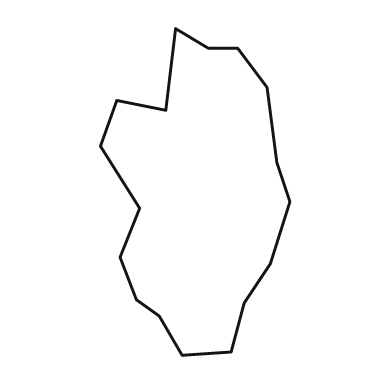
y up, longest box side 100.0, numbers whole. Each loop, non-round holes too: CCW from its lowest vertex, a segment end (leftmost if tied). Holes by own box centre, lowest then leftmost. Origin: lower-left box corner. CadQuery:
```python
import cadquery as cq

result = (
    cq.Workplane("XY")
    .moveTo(25.0, 0.0)
    .lineTo(40.0, 1.0)
    .lineTo(44.0, 16.0)
    .lineTo(52.0, 28.0)
    .lineTo(58.0, 47.0)
    .lineTo(54.0, 59.0)
    .lineTo(51.0, 82.0)
    .lineTo(42.0, 94.0)
    .lineTo(33.0, 94.0)
    .lineTo(23.0, 100.0)
    .lineTo(20.0, 75.0)
    .lineTo(5.0, 78.0)
    .lineTo(0.0, 64.0)
    .lineTo(12.0, 45.0)
    .lineTo(6.0, 30.0)
    .lineTo(11.0, 17.0)
    .lineTo(18.0, 12.0)
    .close()
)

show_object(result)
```